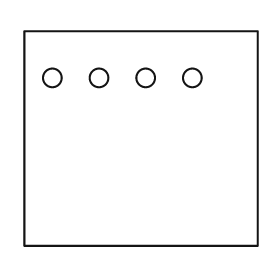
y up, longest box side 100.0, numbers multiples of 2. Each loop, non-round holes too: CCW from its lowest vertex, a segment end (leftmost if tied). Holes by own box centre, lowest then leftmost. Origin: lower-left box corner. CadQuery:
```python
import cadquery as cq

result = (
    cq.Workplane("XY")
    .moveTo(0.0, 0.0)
    .lineTo(100.0, 0.0)
    .lineTo(100.0, 92.0)
    .lineTo(0.0, 92.0)
    .close()
    .moveTo(12.0, 72.0)
    .circle(4.0)
    .moveTo(32.0, 72.0)
    .circle(4.0)
    .moveTo(52.0, 72.0)
    .circle(4.0)
    .moveTo(72.0, 72.0)
    .circle(4.0)
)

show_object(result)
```